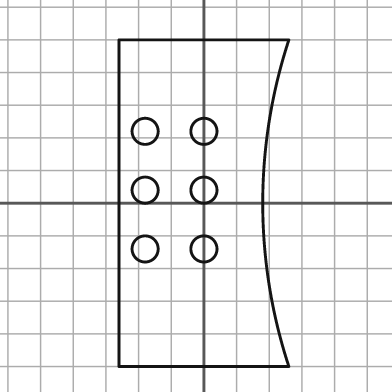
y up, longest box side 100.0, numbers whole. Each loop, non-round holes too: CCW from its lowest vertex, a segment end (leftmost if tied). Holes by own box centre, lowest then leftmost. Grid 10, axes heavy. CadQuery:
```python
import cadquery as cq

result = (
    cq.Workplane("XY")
    .moveTo(-26.0, -50.0)
    .lineTo(26.0, -50.0)
    .threePointArc((18.0, 0.0), (26.0, 50.0))
    .lineTo(-26.0, 50.0)
    .close()
    .moveTo(-18.0, -14.0)
    .circle(4.0)
    .moveTo(0.0, -14.0)
    .circle(4.0)
    .moveTo(-18.0, 4.0)
    .circle(4.0)
    .moveTo(0.0, 4.0)
    .circle(4.0)
    .moveTo(-18.0, 22.0)
    .circle(4.0)
    .moveTo(0.0, 22.0)
    .circle(4.0)
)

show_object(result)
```